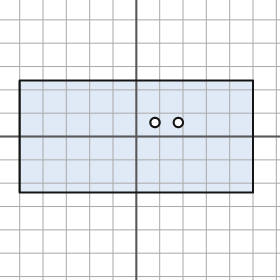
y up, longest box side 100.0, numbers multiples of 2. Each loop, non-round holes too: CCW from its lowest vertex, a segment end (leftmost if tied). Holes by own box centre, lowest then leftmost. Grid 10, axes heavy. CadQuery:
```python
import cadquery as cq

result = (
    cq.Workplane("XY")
    .moveTo(-50.0, -24.0)
    .lineTo(50.0, -24.0)
    .lineTo(50.0, 24.0)
    .lineTo(-50.0, 24.0)
    .close()
    .moveTo(8.0, 6.0)
    .circle(2.0)
    .moveTo(18.0, 6.0)
    .circle(2.0)
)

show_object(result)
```